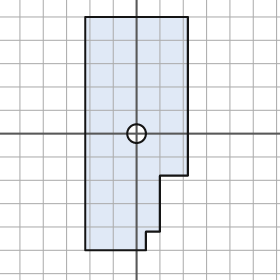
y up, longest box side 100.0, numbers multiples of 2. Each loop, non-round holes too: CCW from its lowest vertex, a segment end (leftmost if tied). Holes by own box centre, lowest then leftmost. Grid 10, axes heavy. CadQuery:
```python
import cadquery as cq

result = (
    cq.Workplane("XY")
    .moveTo(-22.0, -50.0)
    .lineTo(4.0, -50.0)
    .lineTo(4.0, -42.0)
    .lineTo(10.0, -42.0)
    .lineTo(10.0, -18.0)
    .lineTo(22.0, -18.0)
    .lineTo(22.0, 50.0)
    .lineTo(-22.0, 50.0)
    .close()
    .moveTo(0.0, 0.0)
    .circle(4.0)
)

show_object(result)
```